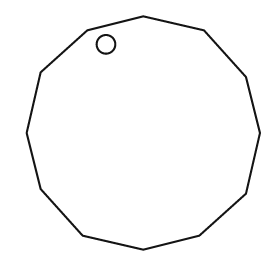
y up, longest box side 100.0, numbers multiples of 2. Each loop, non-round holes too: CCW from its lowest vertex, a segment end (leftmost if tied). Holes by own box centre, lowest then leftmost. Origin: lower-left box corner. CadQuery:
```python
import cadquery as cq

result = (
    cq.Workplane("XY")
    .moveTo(50.0, 0.0)
    .lineTo(74.0, 6.0)
    .lineTo(94.0, 24.0)
    .lineTo(100.0, 50.0)
    .lineTo(94.0, 74.0)
    .lineTo(76.0, 94.0)
    .lineTo(50.0, 100.0)
    .lineTo(26.0, 94.0)
    .lineTo(6.0, 76.0)
    .lineTo(0.0, 50.0)
    .lineTo(6.0, 26.0)
    .lineTo(24.0, 6.0)
    .close()
    .moveTo(34.0, 88.0)
    .circle(4.0)
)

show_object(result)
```